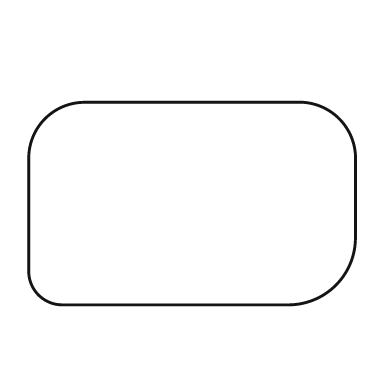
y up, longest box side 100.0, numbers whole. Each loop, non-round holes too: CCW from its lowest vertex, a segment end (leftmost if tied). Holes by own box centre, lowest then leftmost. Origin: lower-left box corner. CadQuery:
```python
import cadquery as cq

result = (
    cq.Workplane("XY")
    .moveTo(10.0, 0.0)
    .lineTo(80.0, 0.0)
    .threePointArc((94.0, 6.0), (100.0, 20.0))
    .lineTo(100.0, 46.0)
    .threePointArc((95.0, 57.0), (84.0, 62.0))
    .lineTo(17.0, 62.0)
    .threePointArc((5.0, 57.0), (0.0, 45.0))
    .lineTo(0.0, 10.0)
    .threePointArc((3.0, 3.0), (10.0, 0.0))
    .close()
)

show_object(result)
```